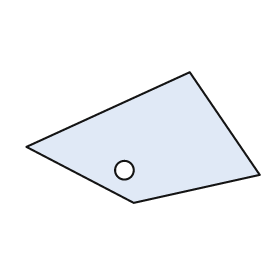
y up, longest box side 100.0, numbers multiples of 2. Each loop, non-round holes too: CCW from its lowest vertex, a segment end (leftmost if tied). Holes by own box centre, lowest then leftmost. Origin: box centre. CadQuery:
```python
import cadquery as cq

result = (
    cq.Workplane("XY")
    .moveTo(-4.0, -28.0)
    .lineTo(50.0, -16.0)
    .lineTo(20.0, 28.0)
    .lineTo(-50.0, -4.0)
    .close()
    .moveTo(-8.0, -14.0)
    .circle(4.0)
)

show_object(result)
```